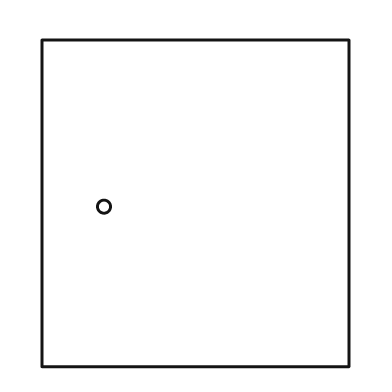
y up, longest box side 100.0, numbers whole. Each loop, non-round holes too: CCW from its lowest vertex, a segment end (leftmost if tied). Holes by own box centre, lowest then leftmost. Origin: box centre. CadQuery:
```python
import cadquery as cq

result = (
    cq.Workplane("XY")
    .moveTo(-47.0, -50.0)
    .lineTo(47.0, -50.0)
    .lineTo(47.0, 50.0)
    .lineTo(-47.0, 50.0)
    .close()
    .moveTo(-28.0, -1.0)
    .circle(2.0)
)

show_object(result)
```